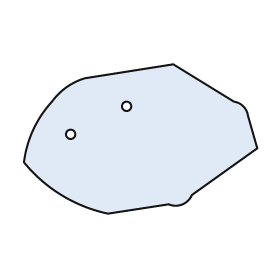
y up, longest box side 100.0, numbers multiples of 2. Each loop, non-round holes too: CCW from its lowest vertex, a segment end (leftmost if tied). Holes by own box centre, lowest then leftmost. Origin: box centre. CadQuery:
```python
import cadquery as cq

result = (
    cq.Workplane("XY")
    .moveTo(-14.0, -32.0)
    .lineTo(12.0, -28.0)
    .threePointArc((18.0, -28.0), (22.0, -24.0))
    .lineTo(50.0, -4.0)
    .lineTo(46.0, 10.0)
    .threePointArc((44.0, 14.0), (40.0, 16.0))
    .lineTo(14.0, 32.0)
    .lineTo(-24.0, 26.0)
    .threePointArc((-32.0, 22.0), (-38.0, 16.0))
    .threePointArc((-46.0, 4.0), (-50.0, -10.0))
    .threePointArc((-34.0, -24.0), (-14.0, -32.0))
    .close()
    .moveTo(-30.0, 2.0)
    .circle(2.0)
    .moveTo(-6.0, 14.0)
    .circle(2.0)
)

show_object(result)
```